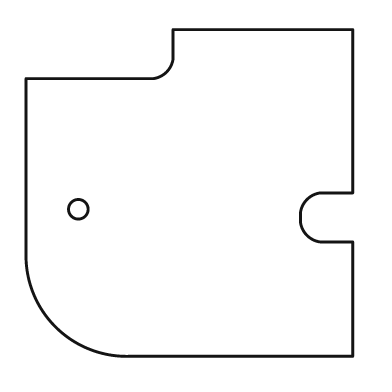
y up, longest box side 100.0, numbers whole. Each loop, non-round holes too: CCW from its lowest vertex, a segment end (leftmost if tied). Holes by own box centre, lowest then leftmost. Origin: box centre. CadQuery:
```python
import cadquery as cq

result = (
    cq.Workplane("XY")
    .moveTo(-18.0, -50.0)
    .lineTo(50.0, -50.0)
    .lineTo(50.0, -15.0)
    .lineTo(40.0, -15.0)
    .threePointArc((36.0, -13.0), (34.0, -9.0))
    .lineTo(34.0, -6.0)
    .threePointArc((36.0, -2.0), (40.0, 0.0))
    .lineTo(50.0, 0.0)
    .lineTo(50.0, 50.0)
    .lineTo(-5.0, 50.0)
    .lineTo(-5.0, 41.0)
    .threePointArc((-7.0, 37.0), (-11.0, 35.0))
    .lineTo(-50.0, 35.0)
    .lineTo(-50.0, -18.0)
    .threePointArc((-41.0, -41.0), (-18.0, -50.0))
    .close()
    .moveTo(-34.0, -5.0)
    .circle(3.0)
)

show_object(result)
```